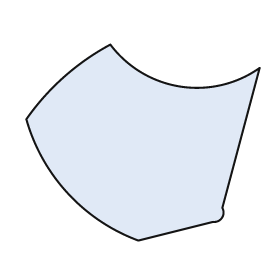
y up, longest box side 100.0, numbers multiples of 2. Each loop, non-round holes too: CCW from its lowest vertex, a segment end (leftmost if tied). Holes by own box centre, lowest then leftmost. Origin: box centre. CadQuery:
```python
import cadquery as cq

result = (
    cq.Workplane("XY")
    .moveTo(-2.0, -42.0)
    .lineTo(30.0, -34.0)
    .threePointArc((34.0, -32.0), (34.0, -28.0))
    .lineTo(50.0, 32.0)
    .threePointArc((16.0, 24.0), (-14.0, 42.0))
    .threePointArc((-34.0, 28.0), (-50.0, 10.0))
    .threePointArc((-32.0, -22.0), (-2.0, -42.0))
    .close()
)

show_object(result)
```